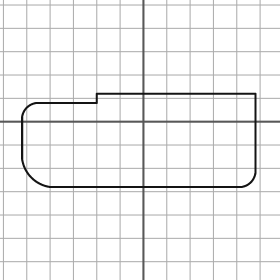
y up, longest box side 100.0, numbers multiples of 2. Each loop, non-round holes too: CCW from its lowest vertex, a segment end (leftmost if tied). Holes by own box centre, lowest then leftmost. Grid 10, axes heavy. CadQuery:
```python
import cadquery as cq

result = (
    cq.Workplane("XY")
    .moveTo(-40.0, -28.0)
    .lineTo(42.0, -28.0)
    .threePointArc((46.0, -26.0), (48.0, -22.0))
    .lineTo(48.0, 12.0)
    .lineTo(-20.0, 12.0)
    .lineTo(-20.0, 8.0)
    .lineTo(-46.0, 8.0)
    .threePointArc((-50.0, 6.0), (-52.0, 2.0))
    .lineTo(-52.0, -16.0)
    .threePointArc((-48.0, -24.0), (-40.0, -28.0))
    .close()
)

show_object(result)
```